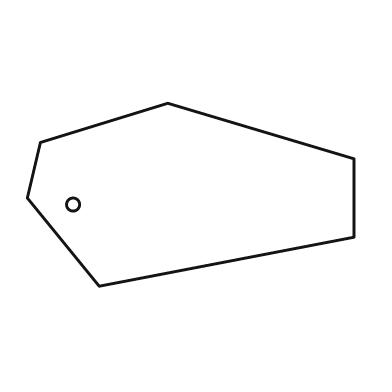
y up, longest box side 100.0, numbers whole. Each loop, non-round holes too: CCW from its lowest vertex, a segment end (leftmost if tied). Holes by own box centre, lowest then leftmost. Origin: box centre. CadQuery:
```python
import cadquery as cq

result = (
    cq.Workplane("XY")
    .moveTo(-28.0, -28.0)
    .lineTo(50.0, -13.0)
    .lineTo(50.0, 11.0)
    .lineTo(-7.0, 28.0)
    .lineTo(-46.0, 16.0)
    .lineTo(-50.0, -1.0)
    .close()
    .moveTo(-36.0, -3.0)
    .circle(2.0)
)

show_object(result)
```